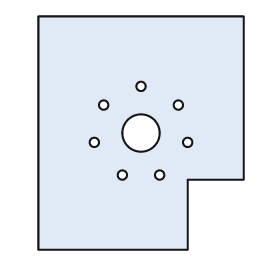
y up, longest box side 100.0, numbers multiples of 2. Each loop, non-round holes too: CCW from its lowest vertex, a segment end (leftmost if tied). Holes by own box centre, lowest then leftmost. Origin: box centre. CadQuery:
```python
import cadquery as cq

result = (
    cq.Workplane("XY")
    .moveTo(-44.0, -50.0)
    .lineTo(20.0, -50.0)
    .lineTo(20.0, -20.0)
    .lineTo(44.0, -20.0)
    .lineTo(44.0, 50.0)
    .lineTo(-44.0, 50.0)
    .close()
    .moveTo(-8.0, -18.0)
    .circle(2.0)
    .moveTo(8.0, -18.0)
    .circle(2.0)
    .moveTo(-20.0, -4.0)
    .circle(2.0)
    .moveTo(20.0, -4.0)
    .circle(2.0)
    .moveTo(0.0, 0.0)
    .circle(8.0)
    .moveTo(-16.0, 12.0)
    .circle(2.0)
    .moveTo(16.0, 12.0)
    .circle(2.0)
    .moveTo(0.0, 20.0)
    .circle(2.0)
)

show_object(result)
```